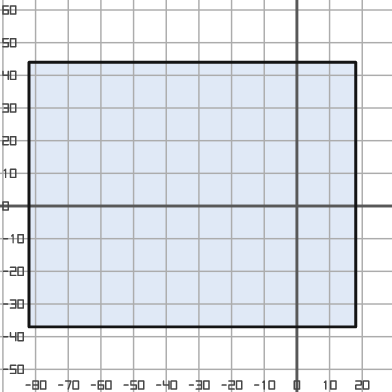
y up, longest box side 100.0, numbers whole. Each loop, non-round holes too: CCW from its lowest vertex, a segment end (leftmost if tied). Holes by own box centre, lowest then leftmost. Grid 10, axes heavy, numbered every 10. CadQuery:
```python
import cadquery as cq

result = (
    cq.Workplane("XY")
    .moveTo(-82.0, -37.0)
    .lineTo(18.0, -37.0)
    .lineTo(18.0, 44.0)
    .lineTo(-82.0, 44.0)
    .close()
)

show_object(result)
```